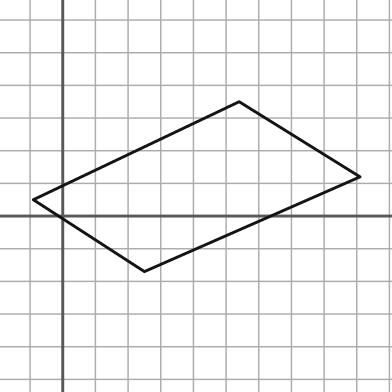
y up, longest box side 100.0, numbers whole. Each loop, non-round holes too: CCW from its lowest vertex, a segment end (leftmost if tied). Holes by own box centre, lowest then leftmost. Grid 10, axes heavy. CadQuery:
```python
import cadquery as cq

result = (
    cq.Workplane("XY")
    .moveTo(25.0, -17.0)
    .lineTo(91.0, 12.0)
    .lineTo(54.0, 35.0)
    .lineTo(-9.0, 5.0)
    .close()
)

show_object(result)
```